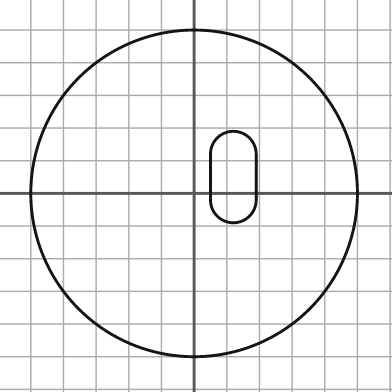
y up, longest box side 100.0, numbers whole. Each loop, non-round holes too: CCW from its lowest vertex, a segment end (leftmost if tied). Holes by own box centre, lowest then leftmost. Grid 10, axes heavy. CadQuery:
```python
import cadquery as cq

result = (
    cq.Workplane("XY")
    .moveTo(0.0, 0.0)
    .circle(50.0)
    .moveTo(5.0, -2.0)
    .threePointArc((12.0, -9.0), (19.0, -2.0))
    .lineTo(19.0, 12.0)
    .threePointArc((12.0, 19.0), (5.0, 12.0))
    .close()
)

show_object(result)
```